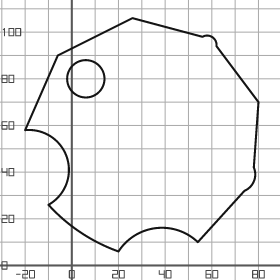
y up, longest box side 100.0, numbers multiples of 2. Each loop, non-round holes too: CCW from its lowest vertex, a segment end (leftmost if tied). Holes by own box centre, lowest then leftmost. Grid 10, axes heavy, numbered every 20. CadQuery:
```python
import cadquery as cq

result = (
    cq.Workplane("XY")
    .moveTo(20.0, 6.0)
    .threePointArc((36.0, 16.0), (54.0, 10.0))
    .lineTo(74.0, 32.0)
    .threePointArc((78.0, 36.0), (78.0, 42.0))
    .lineTo(80.0, 70.0)
    .lineTo(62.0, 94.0)
    .threePointArc((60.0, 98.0), (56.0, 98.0))
    .lineTo(26.0, 106.0)
    .lineTo(-6.0, 90.0)
    .lineTo(-20.0, 58.0)
    .threePointArc((-2.0, 46.0), (-10.0, 26.0))
    .threePointArc((4.0, 14.0), (20.0, 6.0))
    .close()
    .moveTo(6.0, 80.0)
    .circle(8.0)
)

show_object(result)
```